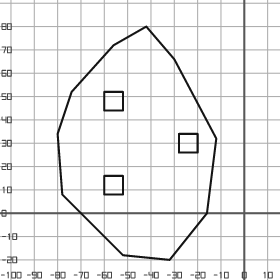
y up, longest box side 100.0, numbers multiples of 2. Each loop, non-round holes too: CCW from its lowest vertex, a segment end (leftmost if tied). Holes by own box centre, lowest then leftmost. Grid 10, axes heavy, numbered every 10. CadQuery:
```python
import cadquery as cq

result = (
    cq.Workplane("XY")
    .moveTo(-32.0, -20.0)
    .lineTo(-16.0, 0.0)
    .lineTo(-12.0, 32.0)
    .lineTo(-30.0, 66.0)
    .lineTo(-42.0, 80.0)
    .lineTo(-56.0, 72.0)
    .lineTo(-74.0, 52.0)
    .lineTo(-80.0, 34.0)
    .lineTo(-78.0, 8.0)
    .lineTo(-52.0, -18.0)
    .close()
    .moveTo(-60.0, 8.0)
    .lineTo(-52.0, 8.0)
    .lineTo(-52.0, 16.0)
    .lineTo(-60.0, 16.0)
    .close()
    .moveTo(-28.0, 26.0)
    .lineTo(-20.0, 26.0)
    .lineTo(-20.0, 34.0)
    .lineTo(-28.0, 34.0)
    .close()
    .moveTo(-60.0, 44.0)
    .lineTo(-52.0, 44.0)
    .lineTo(-52.0, 52.0)
    .lineTo(-60.0, 52.0)
    .close()
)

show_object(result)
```